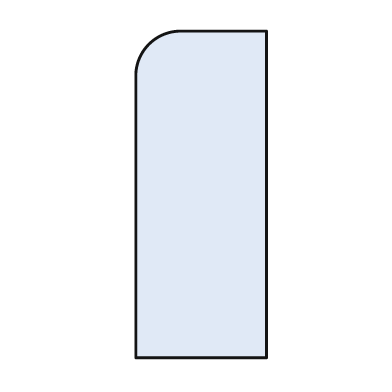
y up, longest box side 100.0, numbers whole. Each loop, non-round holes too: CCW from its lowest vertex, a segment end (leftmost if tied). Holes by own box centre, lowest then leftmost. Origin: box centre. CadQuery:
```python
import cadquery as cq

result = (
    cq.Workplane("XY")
    .moveTo(-20.0, -50.0)
    .lineTo(20.0, -50.0)
    .lineTo(20.0, 50.0)
    .lineTo(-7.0, 50.0)
    .threePointArc((-16.0, 46.0), (-20.0, 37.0))
    .close()
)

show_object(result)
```